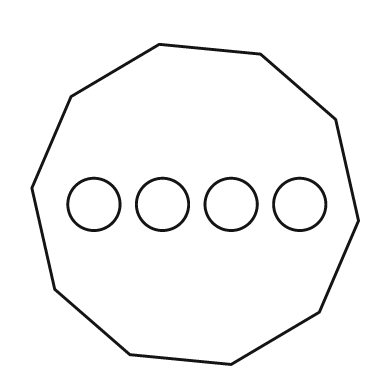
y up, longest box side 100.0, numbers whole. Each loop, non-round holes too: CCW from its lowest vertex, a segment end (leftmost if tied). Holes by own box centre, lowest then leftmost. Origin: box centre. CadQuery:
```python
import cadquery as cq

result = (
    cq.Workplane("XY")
    .moveTo(11.0, -49.0)
    .lineTo(38.0, -33.0)
    .lineTo(50.0, -5.0)
    .lineTo(43.0, 26.0)
    .lineTo(20.0, 46.0)
    .lineTo(-11.0, 49.0)
    .lineTo(-38.0, 33.0)
    .lineTo(-50.0, 5.0)
    .lineTo(-43.0, -26.0)
    .lineTo(-20.0, -46.0)
    .close()
    .moveTo(-31.0, 0.0)
    .circle(8.0)
    .moveTo(-10.0, 0.0)
    .circle(8.0)
    .moveTo(11.0, 0.0)
    .circle(8.0)
    .moveTo(32.0, 0.0)
    .circle(8.0)
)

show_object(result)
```